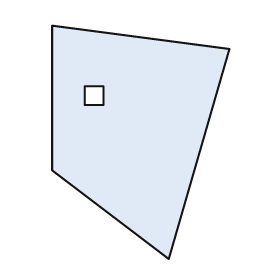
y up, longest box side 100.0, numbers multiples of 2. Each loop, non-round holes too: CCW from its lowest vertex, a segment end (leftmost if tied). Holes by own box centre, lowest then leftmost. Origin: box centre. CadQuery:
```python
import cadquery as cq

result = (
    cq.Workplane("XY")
    .moveTo(12.0, -50.0)
    .lineTo(38.0, 40.0)
    .lineTo(-38.0, 50.0)
    .lineTo(-38.0, -12.0)
    .close()
    .moveTo(-24.0, 16.0)
    .lineTo(-16.0, 16.0)
    .lineTo(-16.0, 24.0)
    .lineTo(-24.0, 24.0)
    .close()
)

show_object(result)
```